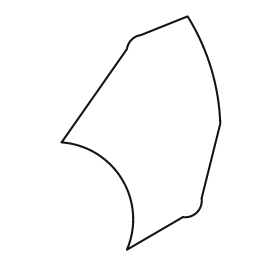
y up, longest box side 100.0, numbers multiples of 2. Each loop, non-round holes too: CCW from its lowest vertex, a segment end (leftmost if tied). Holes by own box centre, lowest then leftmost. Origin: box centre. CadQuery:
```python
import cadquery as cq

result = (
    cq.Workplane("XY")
    .moveTo(-6.0, -50.0)
    .lineTo(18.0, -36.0)
    .threePointArc((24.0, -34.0), (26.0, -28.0))
    .lineTo(34.0, 4.0)
    .threePointArc((30.0, 28.0), (20.0, 50.0))
    .lineTo(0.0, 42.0)
    .threePointArc((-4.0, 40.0), (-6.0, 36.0))
    .lineTo(-34.0, -4.0)
    .threePointArc((-8.0, -20.0), (-6.0, -50.0))
    .close()
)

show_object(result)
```